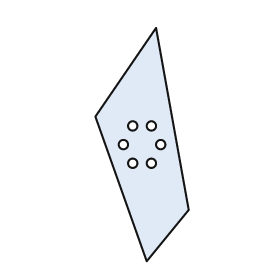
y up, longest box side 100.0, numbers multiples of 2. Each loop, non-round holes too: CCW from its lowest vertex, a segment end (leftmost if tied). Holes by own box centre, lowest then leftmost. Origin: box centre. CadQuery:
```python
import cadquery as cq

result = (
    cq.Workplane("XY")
    .moveTo(2.0, -50.0)
    .lineTo(20.0, -28.0)
    .lineTo(6.0, 50.0)
    .lineTo(-20.0, 12.0)
    .close()
    .moveTo(-4.0, -8.0)
    .circle(2.0)
    .moveTo(4.0, -8.0)
    .circle(2.0)
    .moveTo(-8.0, 0.0)
    .circle(2.0)
    .moveTo(8.0, 0.0)
    .circle(2.0)
    .moveTo(-4.0, 8.0)
    .circle(2.0)
    .moveTo(4.0, 8.0)
    .circle(2.0)
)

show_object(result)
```